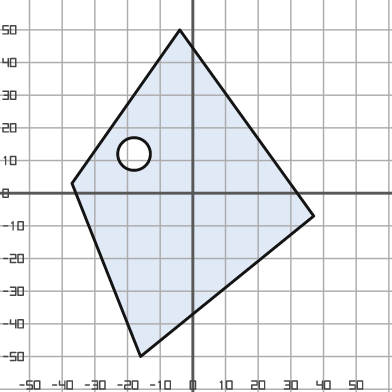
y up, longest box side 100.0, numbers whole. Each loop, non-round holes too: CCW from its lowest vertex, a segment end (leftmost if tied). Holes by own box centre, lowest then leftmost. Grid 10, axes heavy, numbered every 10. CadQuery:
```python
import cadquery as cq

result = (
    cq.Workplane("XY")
    .moveTo(-16.0, -50.0)
    .lineTo(37.0, -7.0)
    .lineTo(-4.0, 50.0)
    .lineTo(-37.0, 3.0)
    .close()
    .moveTo(-18.0, 12.0)
    .circle(5.0)
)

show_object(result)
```